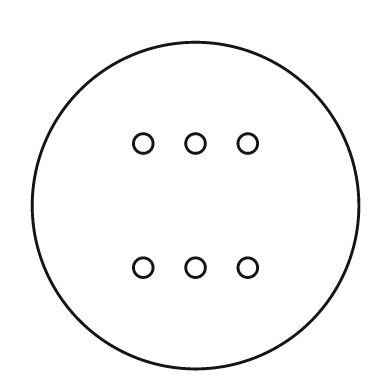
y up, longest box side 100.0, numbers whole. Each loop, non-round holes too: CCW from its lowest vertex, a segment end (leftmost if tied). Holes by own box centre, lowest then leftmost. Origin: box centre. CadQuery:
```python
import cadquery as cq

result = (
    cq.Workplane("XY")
    .moveTo(0.0, 0.0)
    .circle(50.0)
    .moveTo(-16.0, -19.0)
    .circle(3.0)
    .moveTo(0.0, -19.0)
    .circle(3.0)
    .moveTo(16.0, -19.0)
    .circle(3.0)
    .moveTo(-16.0, 19.0)
    .circle(3.0)
    .moveTo(0.0, 19.0)
    .circle(3.0)
    .moveTo(16.0, 19.0)
    .circle(3.0)
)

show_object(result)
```